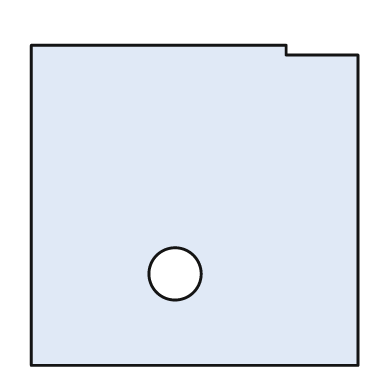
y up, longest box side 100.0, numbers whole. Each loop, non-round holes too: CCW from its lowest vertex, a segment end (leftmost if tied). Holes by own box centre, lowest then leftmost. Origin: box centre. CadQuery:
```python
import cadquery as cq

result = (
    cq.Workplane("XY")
    .moveTo(-50.0, -49.0)
    .lineTo(50.0, -49.0)
    .lineTo(50.0, 46.0)
    .lineTo(28.0, 46.0)
    .lineTo(28.0, 49.0)
    .lineTo(-50.0, 49.0)
    .close()
    .moveTo(-6.0, -21.0)
    .circle(8.0)
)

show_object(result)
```